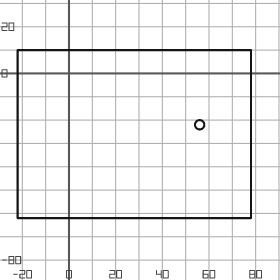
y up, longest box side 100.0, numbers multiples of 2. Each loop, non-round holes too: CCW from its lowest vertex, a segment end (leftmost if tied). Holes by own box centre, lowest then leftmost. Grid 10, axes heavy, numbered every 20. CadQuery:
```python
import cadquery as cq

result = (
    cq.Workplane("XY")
    .moveTo(-22.0, -62.0)
    .lineTo(78.0, -62.0)
    .lineTo(78.0, 10.0)
    .lineTo(-22.0, 10.0)
    .close()
    .moveTo(56.0, -22.0)
    .circle(2.0)
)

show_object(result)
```